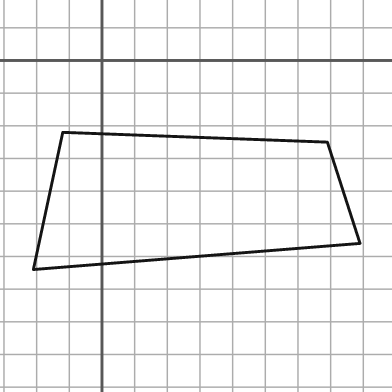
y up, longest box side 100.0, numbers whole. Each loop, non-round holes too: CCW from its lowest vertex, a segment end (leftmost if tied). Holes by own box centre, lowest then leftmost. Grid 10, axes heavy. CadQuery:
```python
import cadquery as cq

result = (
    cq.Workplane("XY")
    .moveTo(-21.0, -64.0)
    .lineTo(79.0, -56.0)
    .lineTo(69.0, -25.0)
    .lineTo(-12.0, -22.0)
    .close()
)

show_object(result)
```